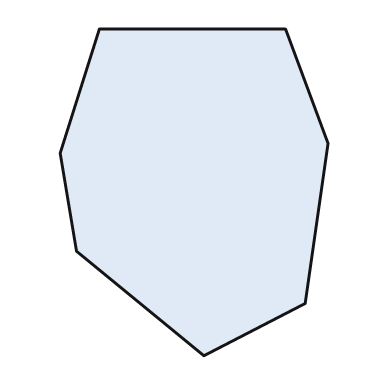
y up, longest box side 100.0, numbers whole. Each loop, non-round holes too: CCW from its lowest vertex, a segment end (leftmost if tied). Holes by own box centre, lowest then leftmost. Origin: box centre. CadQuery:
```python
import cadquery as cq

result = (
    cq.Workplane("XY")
    .moveTo(3.0, -50.0)
    .lineTo(34.0, -34.0)
    .lineTo(41.0, 15.0)
    .lineTo(28.0, 50.0)
    .lineTo(-29.0, 50.0)
    .lineTo(-41.0, 12.0)
    .lineTo(-36.0, -18.0)
    .close()
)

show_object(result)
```